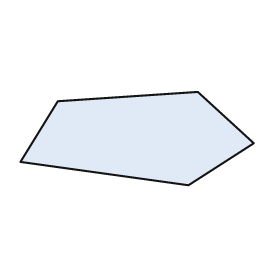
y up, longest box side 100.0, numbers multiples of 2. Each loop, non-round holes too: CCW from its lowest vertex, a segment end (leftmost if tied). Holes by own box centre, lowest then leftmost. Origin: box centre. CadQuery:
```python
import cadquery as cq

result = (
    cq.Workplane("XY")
    .moveTo(22.0, -20.0)
    .lineTo(50.0, -2.0)
    .lineTo(26.0, 20.0)
    .lineTo(-34.0, 16.0)
    .lineTo(-50.0, -10.0)
    .close()
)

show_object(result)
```